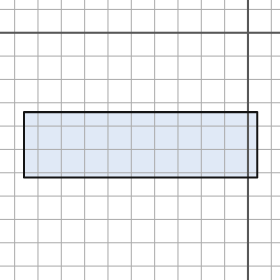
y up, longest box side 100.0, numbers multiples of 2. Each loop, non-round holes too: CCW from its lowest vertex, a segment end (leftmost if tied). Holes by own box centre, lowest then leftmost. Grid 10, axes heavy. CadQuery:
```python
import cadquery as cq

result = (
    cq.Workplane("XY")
    .moveTo(-96.0, -62.0)
    .lineTo(4.0, -62.0)
    .lineTo(4.0, -34.0)
    .lineTo(-96.0, -34.0)
    .close()
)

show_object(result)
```